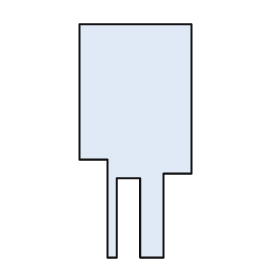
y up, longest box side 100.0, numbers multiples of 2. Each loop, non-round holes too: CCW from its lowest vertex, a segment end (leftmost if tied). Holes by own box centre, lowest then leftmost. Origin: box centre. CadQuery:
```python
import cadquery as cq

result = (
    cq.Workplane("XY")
    .moveTo(-12.0, -50.0)
    .lineTo(-8.0, -50.0)
    .lineTo(-8.0, -16.0)
    .lineTo(2.0, -16.0)
    .lineTo(2.0, -50.0)
    .lineTo(12.0, -50.0)
    .lineTo(12.0, -14.0)
    .lineTo(24.0, -14.0)
    .lineTo(24.0, 50.0)
    .lineTo(-24.0, 50.0)
    .lineTo(-24.0, -8.0)
    .lineTo(-12.0, -8.0)
    .close()
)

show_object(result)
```